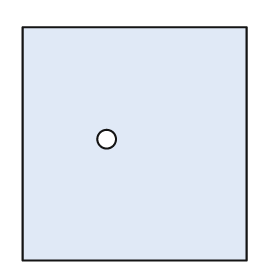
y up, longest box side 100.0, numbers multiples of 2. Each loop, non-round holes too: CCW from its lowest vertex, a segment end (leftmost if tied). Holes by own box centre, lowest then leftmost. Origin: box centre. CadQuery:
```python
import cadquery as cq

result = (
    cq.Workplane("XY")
    .moveTo(-48.0, -50.0)
    .lineTo(48.0, -50.0)
    .lineTo(48.0, 50.0)
    .lineTo(-48.0, 50.0)
    .close()
    .moveTo(-12.0, 2.0)
    .circle(4.0)
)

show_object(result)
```